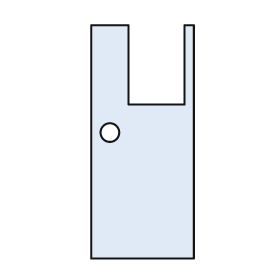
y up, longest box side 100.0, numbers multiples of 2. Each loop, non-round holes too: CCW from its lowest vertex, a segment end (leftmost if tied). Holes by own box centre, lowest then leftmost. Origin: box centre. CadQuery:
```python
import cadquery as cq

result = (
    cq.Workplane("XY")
    .moveTo(-22.0, -50.0)
    .lineTo(22.0, -50.0)
    .lineTo(22.0, 50.0)
    .lineTo(18.0, 50.0)
    .lineTo(18.0, 16.0)
    .lineTo(-6.0, 16.0)
    .lineTo(-6.0, 50.0)
    .lineTo(-22.0, 50.0)
    .close()
    .moveTo(-14.0, 4.0)
    .circle(4.0)
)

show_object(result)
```